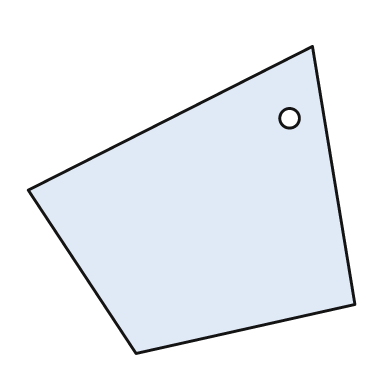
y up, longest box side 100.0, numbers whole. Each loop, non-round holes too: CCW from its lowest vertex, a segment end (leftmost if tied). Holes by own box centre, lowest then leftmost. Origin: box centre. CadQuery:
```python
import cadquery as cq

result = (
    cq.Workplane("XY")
    .moveTo(-17.0, -47.0)
    .lineTo(50.0, -32.0)
    .lineTo(37.0, 47.0)
    .lineTo(-50.0, 3.0)
    .close()
    .moveTo(30.0, 25.0)
    .circle(3.0)
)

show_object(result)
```